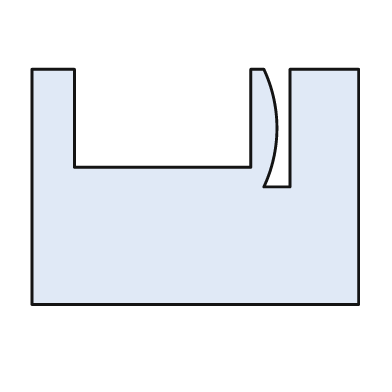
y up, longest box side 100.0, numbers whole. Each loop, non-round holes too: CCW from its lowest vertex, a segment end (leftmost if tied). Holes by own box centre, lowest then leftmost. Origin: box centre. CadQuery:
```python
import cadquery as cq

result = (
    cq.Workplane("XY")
    .moveTo(-50.0, -36.0)
    .lineTo(50.0, -36.0)
    .lineTo(50.0, 36.0)
    .lineTo(29.0, 36.0)
    .lineTo(29.0, 0.0)
    .lineTo(21.0, 0.0)
    .threePointArc((25.0, 18.0), (21.0, 36.0))
    .lineTo(17.0, 36.0)
    .lineTo(17.0, 6.0)
    .lineTo(-37.0, 6.0)
    .lineTo(-37.0, 36.0)
    .lineTo(-50.0, 36.0)
    .close()
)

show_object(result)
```